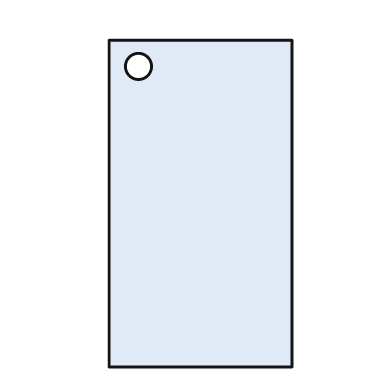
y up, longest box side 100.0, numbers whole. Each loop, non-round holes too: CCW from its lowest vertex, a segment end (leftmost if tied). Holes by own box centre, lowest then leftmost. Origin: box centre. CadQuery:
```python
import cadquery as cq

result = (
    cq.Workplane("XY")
    .moveTo(-28.0, -50.0)
    .lineTo(28.0, -50.0)
    .lineTo(28.0, 50.0)
    .lineTo(-28.0, 50.0)
    .close()
    .moveTo(-19.0, 42.0)
    .circle(4.0)
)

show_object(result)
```